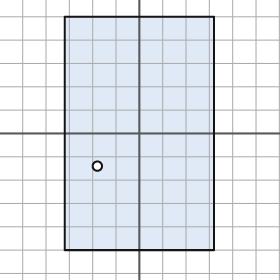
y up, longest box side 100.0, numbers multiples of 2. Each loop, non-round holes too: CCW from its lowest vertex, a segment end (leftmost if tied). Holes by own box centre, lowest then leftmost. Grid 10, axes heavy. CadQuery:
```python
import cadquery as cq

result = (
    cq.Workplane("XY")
    .moveTo(-32.0, -50.0)
    .lineTo(32.0, -50.0)
    .lineTo(32.0, 50.0)
    .lineTo(-32.0, 50.0)
    .close()
    .moveTo(-18.0, -14.0)
    .circle(2.0)
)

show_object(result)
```